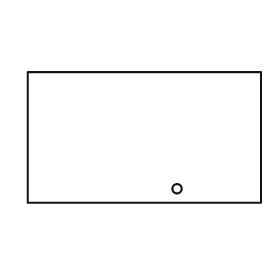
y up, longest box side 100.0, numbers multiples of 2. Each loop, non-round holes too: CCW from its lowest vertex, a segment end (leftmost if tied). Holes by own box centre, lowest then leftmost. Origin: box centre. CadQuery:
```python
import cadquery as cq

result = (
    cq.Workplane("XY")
    .moveTo(-50.0, -28.0)
    .lineTo(50.0, -28.0)
    .lineTo(50.0, 28.0)
    .lineTo(-50.0, 28.0)
    .close()
    .moveTo(14.0, -22.0)
    .circle(2.0)
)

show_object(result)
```